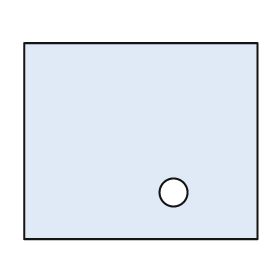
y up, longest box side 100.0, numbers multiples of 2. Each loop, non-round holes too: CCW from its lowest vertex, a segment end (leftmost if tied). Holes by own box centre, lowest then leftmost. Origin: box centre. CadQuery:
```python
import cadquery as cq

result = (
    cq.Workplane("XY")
    .moveTo(-50.0, -42.0)
    .lineTo(50.0, -42.0)
    .lineTo(50.0, 42.0)
    .lineTo(-50.0, 42.0)
    .close()
    .moveTo(14.0, -22.0)
    .circle(6.0)
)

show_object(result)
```